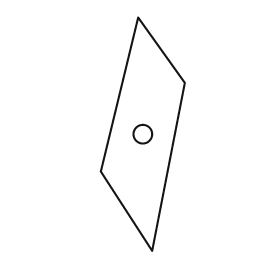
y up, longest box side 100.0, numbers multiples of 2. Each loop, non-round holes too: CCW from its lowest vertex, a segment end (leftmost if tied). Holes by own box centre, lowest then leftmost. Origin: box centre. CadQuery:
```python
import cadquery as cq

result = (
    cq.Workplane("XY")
    .moveTo(4.0, -50.0)
    .lineTo(18.0, 22.0)
    .lineTo(-2.0, 50.0)
    .lineTo(-18.0, -16.0)
    .close()
    .moveTo(0.0, 0.0)
    .circle(4.0)
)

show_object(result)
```